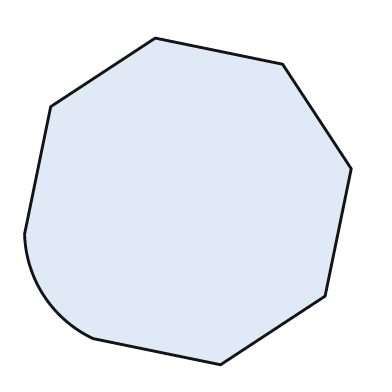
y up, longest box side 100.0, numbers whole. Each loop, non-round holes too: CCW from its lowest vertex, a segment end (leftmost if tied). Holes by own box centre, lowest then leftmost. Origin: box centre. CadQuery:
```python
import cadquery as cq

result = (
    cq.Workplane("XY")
    .moveTo(10.0, -50.0)
    .lineTo(42.0, -29.0)
    .lineTo(50.0, 10.0)
    .lineTo(29.0, 42.0)
    .lineTo(-10.0, 50.0)
    .lineTo(-42.0, 29.0)
    .lineTo(-50.0, -10.0)
    .threePointArc((-44.0, -29.0), (-29.0, -42.0))
    .close()
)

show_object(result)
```